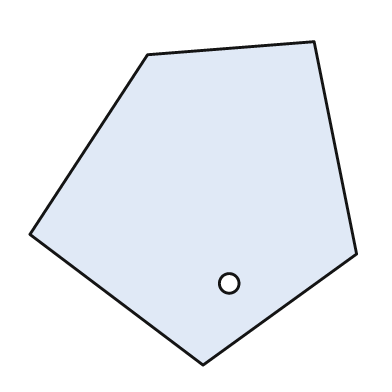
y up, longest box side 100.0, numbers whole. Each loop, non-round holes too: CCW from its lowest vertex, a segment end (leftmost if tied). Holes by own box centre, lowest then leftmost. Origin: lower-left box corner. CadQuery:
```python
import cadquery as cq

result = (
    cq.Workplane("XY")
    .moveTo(53.0, 0.0)
    .lineTo(100.0, 34.0)
    .lineTo(87.0, 99.0)
    .lineTo(36.0, 95.0)
    .lineTo(0.0, 40.0)
    .close()
    .moveTo(61.0, 25.0)
    .circle(3.0)
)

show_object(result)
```